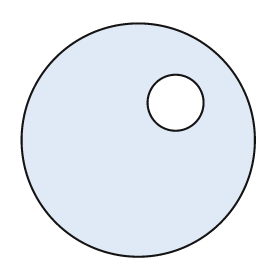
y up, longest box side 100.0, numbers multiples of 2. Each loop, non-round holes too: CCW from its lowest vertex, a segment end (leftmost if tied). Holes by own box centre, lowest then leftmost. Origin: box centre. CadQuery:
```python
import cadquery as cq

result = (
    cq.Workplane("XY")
    .moveTo(0.0, 0.0)
    .circle(50.0)
    .moveTo(16.0, 16.0)
    .circle(12.0)
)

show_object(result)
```